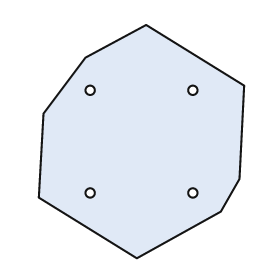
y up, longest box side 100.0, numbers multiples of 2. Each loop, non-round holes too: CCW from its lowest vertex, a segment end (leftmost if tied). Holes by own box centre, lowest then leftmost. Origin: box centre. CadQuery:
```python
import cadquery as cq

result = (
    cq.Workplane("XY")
    .moveTo(-2.0, -50.0)
    .lineTo(34.0, -30.0)
    .lineTo(42.0, -16.0)
    .lineTo(44.0, 24.0)
    .lineTo(2.0, 50.0)
    .lineTo(-24.0, 36.0)
    .lineTo(-42.0, 12.0)
    .lineTo(-44.0, -24.0)
    .close()
    .moveTo(-22.0, -22.0)
    .circle(2.0)
    .moveTo(22.0, -22.0)
    .circle(2.0)
    .moveTo(-22.0, 22.0)
    .circle(2.0)
    .moveTo(22.0, 22.0)
    .circle(2.0)
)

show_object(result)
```